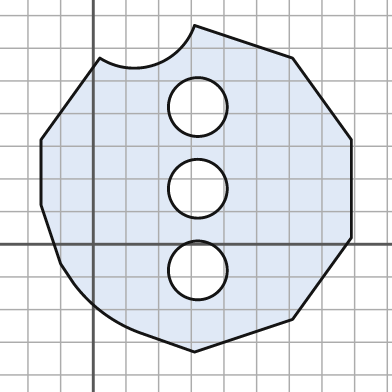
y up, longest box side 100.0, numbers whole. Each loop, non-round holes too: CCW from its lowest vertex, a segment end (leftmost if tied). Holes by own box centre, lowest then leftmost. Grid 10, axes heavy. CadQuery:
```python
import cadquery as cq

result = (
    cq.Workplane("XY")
    .moveTo(31.0, -33.0)
    .lineTo(61.0, -23.0)
    .lineTo(79.0, 2.0)
    .lineTo(79.0, 32.0)
    .lineTo(61.0, 57.0)
    .lineTo(31.0, 67.0)
    .threePointArc((19.0, 55.0), (2.0, 57.0))
    .lineTo(-16.0, 32.0)
    .lineTo(-16.0, 12.0)
    .lineTo(-10.0, -6.0)
    .lineTo(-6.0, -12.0)
    .threePointArc((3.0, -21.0), (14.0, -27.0))
    .close()
    .moveTo(32.0, -8.0)
    .circle(9.0)
    .moveTo(32.0, 17.0)
    .circle(9.0)
    .moveTo(32.0, 42.0)
    .circle(9.0)
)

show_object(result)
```